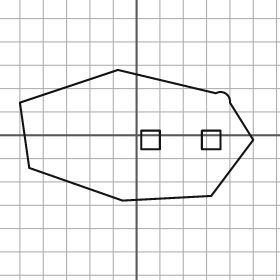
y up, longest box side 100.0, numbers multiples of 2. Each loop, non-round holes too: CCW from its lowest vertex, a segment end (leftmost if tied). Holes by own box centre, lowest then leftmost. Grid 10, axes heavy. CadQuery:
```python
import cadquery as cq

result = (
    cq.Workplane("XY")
    .moveTo(-6.0, -28.0)
    .lineTo(32.0, -26.0)
    .lineTo(50.0, -2.0)
    .lineTo(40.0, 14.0)
    .threePointArc((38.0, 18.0), (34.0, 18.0))
    .lineTo(-8.0, 28.0)
    .lineTo(-50.0, 14.0)
    .lineTo(-46.0, -14.0)
    .close()
    .moveTo(2.0, -6.0)
    .lineTo(10.0, -6.0)
    .lineTo(10.0, 2.0)
    .lineTo(2.0, 2.0)
    .close()
    .moveTo(28.0, -6.0)
    .lineTo(36.0, -6.0)
    .lineTo(36.0, 2.0)
    .lineTo(28.0, 2.0)
    .close()
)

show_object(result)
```